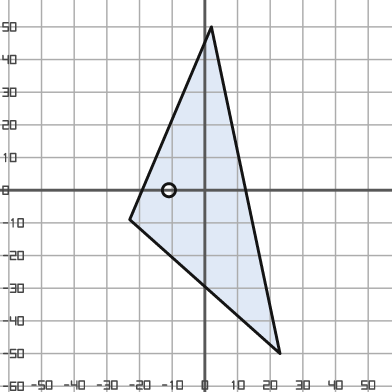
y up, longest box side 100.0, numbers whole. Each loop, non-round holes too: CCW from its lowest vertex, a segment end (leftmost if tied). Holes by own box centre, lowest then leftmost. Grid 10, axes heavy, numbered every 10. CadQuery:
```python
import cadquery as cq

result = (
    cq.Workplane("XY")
    .moveTo(23.0, -50.0)
    .lineTo(2.0, 50.0)
    .lineTo(-23.0, -9.0)
    .close()
    .moveTo(-11.0, 0.0)
    .circle(2.0)
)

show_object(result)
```